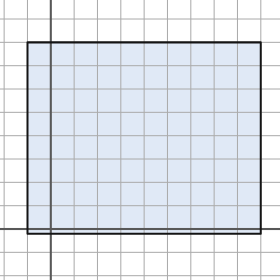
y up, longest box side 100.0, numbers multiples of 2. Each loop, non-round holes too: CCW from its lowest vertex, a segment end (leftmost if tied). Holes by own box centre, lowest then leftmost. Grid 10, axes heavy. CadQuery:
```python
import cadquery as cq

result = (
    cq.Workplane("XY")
    .moveTo(-10.0, -2.0)
    .lineTo(90.0, -2.0)
    .lineTo(90.0, 80.0)
    .lineTo(-10.0, 80.0)
    .close()
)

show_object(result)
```